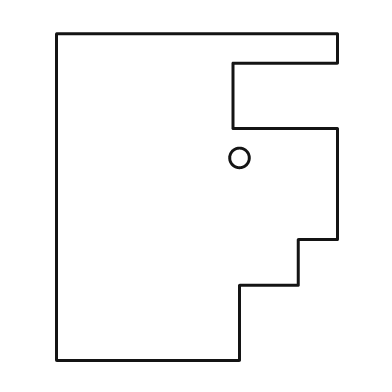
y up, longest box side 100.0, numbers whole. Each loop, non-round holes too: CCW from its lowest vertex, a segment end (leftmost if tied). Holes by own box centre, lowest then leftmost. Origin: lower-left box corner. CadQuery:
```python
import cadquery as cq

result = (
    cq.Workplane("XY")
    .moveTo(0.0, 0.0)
    .lineTo(56.0, 0.0)
    .lineTo(56.0, 23.0)
    .lineTo(74.0, 23.0)
    .lineTo(74.0, 37.0)
    .lineTo(86.0, 37.0)
    .lineTo(86.0, 71.0)
    .lineTo(54.0, 71.0)
    .lineTo(54.0, 91.0)
    .lineTo(86.0, 91.0)
    .lineTo(86.0, 100.0)
    .lineTo(0.0, 100.0)
    .close()
    .moveTo(56.0, 62.0)
    .circle(3.0)
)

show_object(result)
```